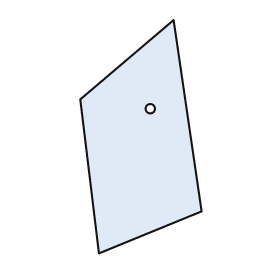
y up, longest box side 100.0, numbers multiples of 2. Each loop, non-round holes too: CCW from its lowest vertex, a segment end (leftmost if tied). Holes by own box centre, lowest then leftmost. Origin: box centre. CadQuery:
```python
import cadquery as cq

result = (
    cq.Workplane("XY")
    .moveTo(-18.0, -50.0)
    .lineTo(26.0, -32.0)
    .lineTo(14.0, 50.0)
    .lineTo(-26.0, 16.0)
    .close()
    .moveTo(4.0, 12.0)
    .circle(2.0)
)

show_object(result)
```